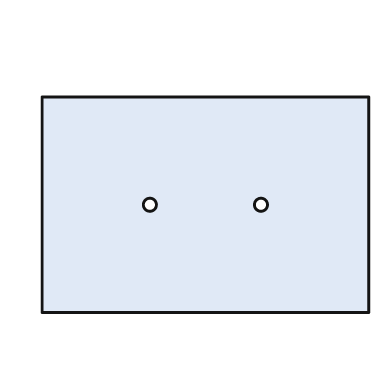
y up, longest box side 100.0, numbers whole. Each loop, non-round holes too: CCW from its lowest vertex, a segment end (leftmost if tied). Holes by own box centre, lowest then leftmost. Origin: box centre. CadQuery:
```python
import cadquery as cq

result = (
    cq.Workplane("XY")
    .moveTo(-50.0, -33.0)
    .lineTo(50.0, -33.0)
    .lineTo(50.0, 33.0)
    .lineTo(-50.0, 33.0)
    .close()
    .moveTo(-17.0, 0.0)
    .circle(2.0)
    .moveTo(17.0, 0.0)
    .circle(2.0)
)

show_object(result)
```